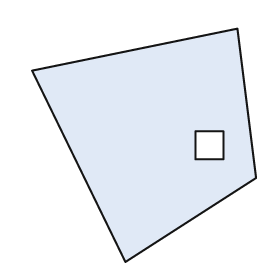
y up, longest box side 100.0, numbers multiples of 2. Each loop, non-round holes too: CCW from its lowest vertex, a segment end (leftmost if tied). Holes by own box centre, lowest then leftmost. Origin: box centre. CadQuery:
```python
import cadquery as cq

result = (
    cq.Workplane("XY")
    .moveTo(-8.0, -50.0)
    .lineTo(48.0, -14.0)
    .lineTo(40.0, 50.0)
    .lineTo(-48.0, 32.0)
    .close()
    .moveTo(22.0, -6.0)
    .lineTo(34.0, -6.0)
    .lineTo(34.0, 6.0)
    .lineTo(22.0, 6.0)
    .close()
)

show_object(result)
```